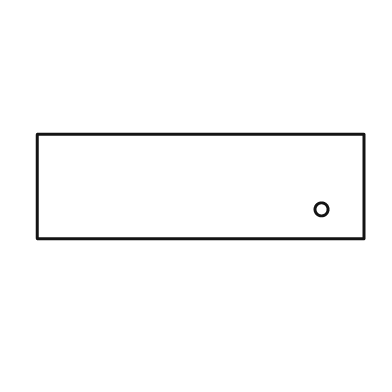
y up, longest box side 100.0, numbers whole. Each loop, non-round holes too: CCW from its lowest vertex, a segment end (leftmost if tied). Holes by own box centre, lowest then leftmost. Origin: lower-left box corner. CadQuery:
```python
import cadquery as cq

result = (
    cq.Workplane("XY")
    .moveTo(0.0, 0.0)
    .lineTo(100.0, 0.0)
    .lineTo(100.0, 32.0)
    .lineTo(0.0, 32.0)
    .close()
    .moveTo(87.0, 9.0)
    .circle(2.0)
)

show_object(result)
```